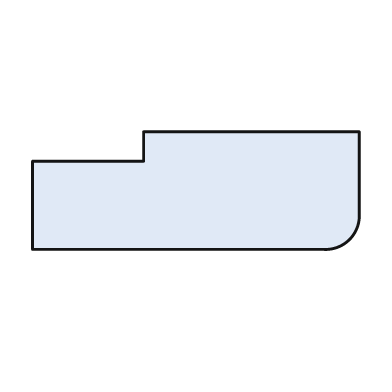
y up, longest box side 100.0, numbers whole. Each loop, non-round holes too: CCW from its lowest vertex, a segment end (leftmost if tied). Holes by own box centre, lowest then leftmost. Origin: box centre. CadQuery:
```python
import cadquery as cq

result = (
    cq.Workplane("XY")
    .moveTo(-50.0, -18.0)
    .lineTo(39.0, -18.0)
    .threePointArc((47.0, -15.0), (50.0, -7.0))
    .lineTo(50.0, 18.0)
    .lineTo(-16.0, 18.0)
    .lineTo(-16.0, 9.0)
    .lineTo(-50.0, 9.0)
    .close()
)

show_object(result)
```